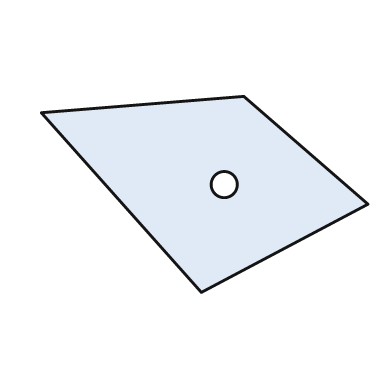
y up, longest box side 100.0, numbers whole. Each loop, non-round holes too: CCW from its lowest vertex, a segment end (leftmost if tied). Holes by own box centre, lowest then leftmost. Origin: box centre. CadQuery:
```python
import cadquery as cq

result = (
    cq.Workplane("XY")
    .moveTo(-1.0, -30.0)
    .lineTo(50.0, -3.0)
    .lineTo(12.0, 30.0)
    .lineTo(-50.0, 25.0)
    .close()
    .moveTo(6.0, 3.0)
    .circle(4.0)
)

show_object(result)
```